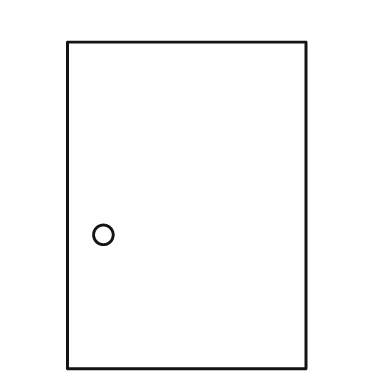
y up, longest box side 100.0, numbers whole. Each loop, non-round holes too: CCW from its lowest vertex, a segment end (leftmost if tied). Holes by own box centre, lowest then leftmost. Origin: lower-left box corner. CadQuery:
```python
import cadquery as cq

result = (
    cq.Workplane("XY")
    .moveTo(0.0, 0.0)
    .lineTo(73.0, 0.0)
    .lineTo(73.0, 100.0)
    .lineTo(0.0, 100.0)
    .close()
    .moveTo(11.0, 41.0)
    .circle(3.0)
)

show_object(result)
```